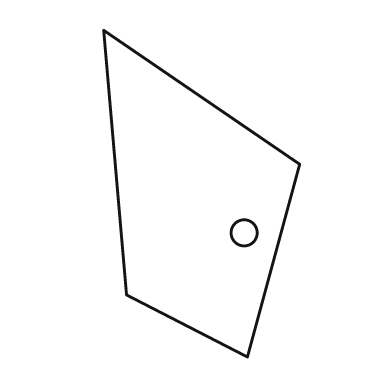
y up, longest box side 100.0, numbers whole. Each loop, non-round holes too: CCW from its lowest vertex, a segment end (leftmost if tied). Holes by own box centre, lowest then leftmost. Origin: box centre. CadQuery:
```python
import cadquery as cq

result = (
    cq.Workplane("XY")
    .moveTo(14.0, -50.0)
    .lineTo(30.0, 9.0)
    .lineTo(-30.0, 50.0)
    .lineTo(-23.0, -31.0)
    .close()
    .moveTo(13.0, -12.0)
    .circle(4.0)
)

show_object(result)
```